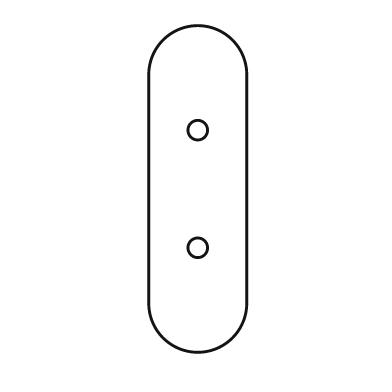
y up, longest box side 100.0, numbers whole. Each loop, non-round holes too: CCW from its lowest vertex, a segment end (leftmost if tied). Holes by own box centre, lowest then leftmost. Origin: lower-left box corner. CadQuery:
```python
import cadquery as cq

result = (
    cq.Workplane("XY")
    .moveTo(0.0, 15.0)
    .threePointArc((15.0, 0.0), (30.0, 15.0))
    .lineTo(30.0, 85.0)
    .threePointArc((15.0, 100.0), (0.0, 85.0))
    .close()
    .moveTo(15.0, 32.0)
    .circle(3.0)
    .moveTo(15.0, 68.0)
    .circle(3.0)
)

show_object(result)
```